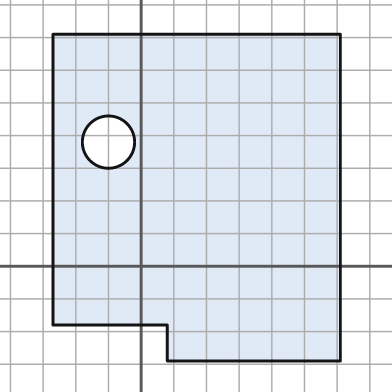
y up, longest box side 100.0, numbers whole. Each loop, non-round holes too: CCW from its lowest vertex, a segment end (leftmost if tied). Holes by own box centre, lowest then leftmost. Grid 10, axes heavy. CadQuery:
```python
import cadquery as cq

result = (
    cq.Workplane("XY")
    .moveTo(8.0, -29.0)
    .lineTo(61.0, -29.0)
    .lineTo(61.0, 71.0)
    .lineTo(-27.0, 71.0)
    .lineTo(-27.0, -18.0)
    .lineTo(8.0, -18.0)
    .close()
    .moveTo(-10.0, 38.0)
    .circle(8.0)
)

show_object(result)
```